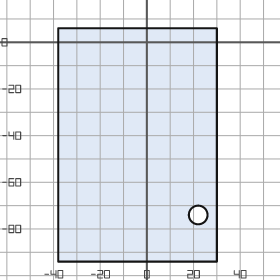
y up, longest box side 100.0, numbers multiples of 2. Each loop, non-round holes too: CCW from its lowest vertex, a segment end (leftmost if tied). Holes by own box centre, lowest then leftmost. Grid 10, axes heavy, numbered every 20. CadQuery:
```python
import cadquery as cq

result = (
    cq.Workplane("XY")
    .moveTo(-38.0, -94.0)
    .lineTo(30.0, -94.0)
    .lineTo(30.0, 6.0)
    .lineTo(-38.0, 6.0)
    .close()
    .moveTo(22.0, -74.0)
    .circle(4.0)
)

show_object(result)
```